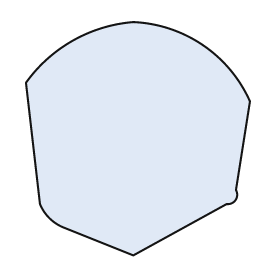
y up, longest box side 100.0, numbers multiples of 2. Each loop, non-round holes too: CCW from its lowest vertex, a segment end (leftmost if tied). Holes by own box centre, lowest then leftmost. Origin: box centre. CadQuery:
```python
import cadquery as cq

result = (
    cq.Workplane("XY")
    .moveTo(-2.0, -50.0)
    .lineTo(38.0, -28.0)
    .threePointArc((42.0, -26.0), (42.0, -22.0))
    .lineTo(48.0, 16.0)
    .threePointArc((28.0, 40.0), (-2.0, 50.0))
    .threePointArc((-28.0, 42.0), (-48.0, 24.0))
    .lineTo(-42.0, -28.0)
    .threePointArc((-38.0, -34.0), (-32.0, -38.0))
    .close()
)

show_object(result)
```